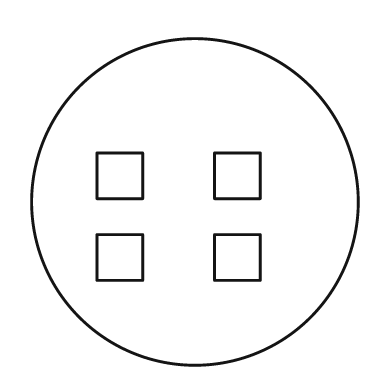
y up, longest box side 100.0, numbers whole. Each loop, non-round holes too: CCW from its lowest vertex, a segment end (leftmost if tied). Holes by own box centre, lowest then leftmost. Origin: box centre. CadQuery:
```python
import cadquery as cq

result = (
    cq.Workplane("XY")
    .moveTo(0.0, 0.0)
    .circle(50.0)
    .moveTo(-30.0, -24.0)
    .lineTo(-16.0, -24.0)
    .lineTo(-16.0, -10.0)
    .lineTo(-30.0, -10.0)
    .close()
    .moveTo(6.0, -24.0)
    .lineTo(20.0, -24.0)
    .lineTo(20.0, -10.0)
    .lineTo(6.0, -10.0)
    .close()
    .moveTo(-30.0, 1.0)
    .lineTo(-16.0, 1.0)
    .lineTo(-16.0, 15.0)
    .lineTo(-30.0, 15.0)
    .close()
    .moveTo(6.0, 1.0)
    .lineTo(20.0, 1.0)
    .lineTo(20.0, 15.0)
    .lineTo(6.0, 15.0)
    .close()
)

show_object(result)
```